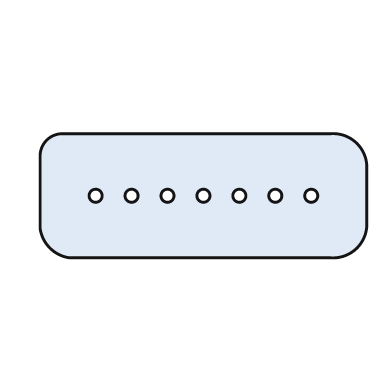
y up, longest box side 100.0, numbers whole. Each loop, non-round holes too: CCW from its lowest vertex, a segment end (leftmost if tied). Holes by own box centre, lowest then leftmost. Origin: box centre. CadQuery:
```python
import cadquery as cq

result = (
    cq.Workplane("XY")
    .moveTo(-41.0, -19.0)
    .lineTo(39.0, -19.0)
    .threePointArc((47.0, -16.0), (50.0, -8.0))
    .lineTo(50.0, 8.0)
    .threePointArc((47.0, 16.0), (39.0, 19.0))
    .lineTo(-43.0, 19.0)
    .threePointArc((-48.0, 17.0), (-50.0, 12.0))
    .lineTo(-50.0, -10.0)
    .threePointArc((-47.0, -16.0), (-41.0, -19.0))
    .close()
    .moveTo(-33.0, 0.0)
    .circle(2.0)
    .moveTo(-22.0, 0.0)
    .circle(2.0)
    .moveTo(-11.0, 0.0)
    .circle(2.0)
    .moveTo(0.0, 0.0)
    .circle(2.0)
    .moveTo(11.0, 0.0)
    .circle(2.0)
    .moveTo(22.0, 0.0)
    .circle(2.0)
    .moveTo(33.0, 0.0)
    .circle(2.0)
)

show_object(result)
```